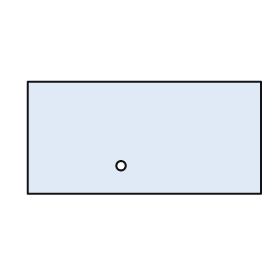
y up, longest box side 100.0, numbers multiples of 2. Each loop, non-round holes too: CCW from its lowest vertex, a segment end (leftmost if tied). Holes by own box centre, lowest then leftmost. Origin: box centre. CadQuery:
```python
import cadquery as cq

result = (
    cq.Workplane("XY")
    .moveTo(-50.0, -24.0)
    .lineTo(50.0, -24.0)
    .lineTo(50.0, 24.0)
    .lineTo(-50.0, 24.0)
    .close()
    .moveTo(-10.0, -12.0)
    .circle(2.0)
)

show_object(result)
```